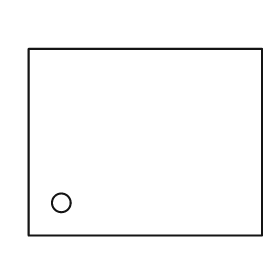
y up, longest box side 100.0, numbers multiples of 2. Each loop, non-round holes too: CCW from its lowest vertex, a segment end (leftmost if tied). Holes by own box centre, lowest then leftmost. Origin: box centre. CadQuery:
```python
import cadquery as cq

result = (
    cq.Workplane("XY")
    .moveTo(-50.0, -40.0)
    .lineTo(50.0, -40.0)
    .lineTo(50.0, 40.0)
    .lineTo(-50.0, 40.0)
    .close()
    .moveTo(-36.0, -26.0)
    .circle(4.0)
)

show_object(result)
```